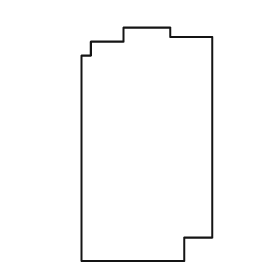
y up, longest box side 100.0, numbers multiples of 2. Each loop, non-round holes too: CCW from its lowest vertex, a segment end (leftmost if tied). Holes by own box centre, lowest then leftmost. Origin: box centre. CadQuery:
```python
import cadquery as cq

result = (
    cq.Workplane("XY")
    .moveTo(-28.0, -50.0)
    .lineTo(16.0, -50.0)
    .lineTo(16.0, -40.0)
    .lineTo(28.0, -40.0)
    .lineTo(28.0, 46.0)
    .lineTo(10.0, 46.0)
    .lineTo(10.0, 50.0)
    .lineTo(-10.0, 50.0)
    .lineTo(-10.0, 44.0)
    .lineTo(-24.0, 44.0)
    .lineTo(-24.0, 38.0)
    .lineTo(-28.0, 38.0)
    .close()
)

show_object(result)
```